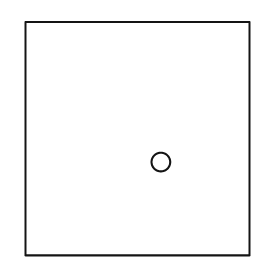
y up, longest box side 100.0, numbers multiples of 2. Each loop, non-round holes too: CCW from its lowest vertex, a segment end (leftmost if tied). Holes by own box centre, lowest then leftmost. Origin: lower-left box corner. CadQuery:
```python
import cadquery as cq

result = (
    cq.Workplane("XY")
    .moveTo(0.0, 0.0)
    .lineTo(96.0, 0.0)
    .lineTo(96.0, 100.0)
    .lineTo(0.0, 100.0)
    .close()
    .moveTo(58.0, 40.0)
    .circle(4.0)
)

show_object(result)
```